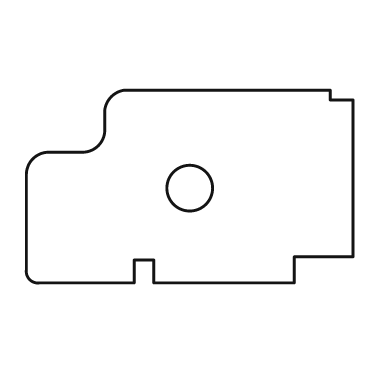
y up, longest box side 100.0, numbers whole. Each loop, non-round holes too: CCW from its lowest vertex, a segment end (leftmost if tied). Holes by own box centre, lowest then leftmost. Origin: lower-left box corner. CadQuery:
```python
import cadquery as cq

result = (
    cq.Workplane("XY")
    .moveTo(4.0, 0.0)
    .lineTo(33.0, 0.0)
    .lineTo(33.0, 7.0)
    .lineTo(39.0, 7.0)
    .lineTo(39.0, 0.0)
    .lineTo(82.0, 0.0)
    .lineTo(82.0, 8.0)
    .lineTo(100.0, 8.0)
    .lineTo(100.0, 56.0)
    .lineTo(93.0, 56.0)
    .lineTo(93.0, 59.0)
    .lineTo(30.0, 59.0)
    .threePointArc((26.0, 57.0), (24.0, 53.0))
    .lineTo(24.0, 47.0)
    .threePointArc((22.0, 42.0), (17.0, 40.0))
    .lineTo(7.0, 40.0)
    .threePointArc((2.0, 38.0), (0.0, 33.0))
    .lineTo(0.0, 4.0)
    .threePointArc((1.0, 1.0), (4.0, 0.0))
    .close()
    .moveTo(50.0, 29.0)
    .circle(7.0)
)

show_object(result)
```